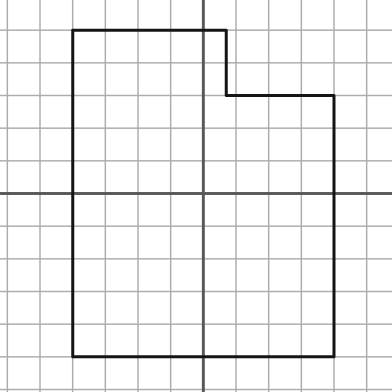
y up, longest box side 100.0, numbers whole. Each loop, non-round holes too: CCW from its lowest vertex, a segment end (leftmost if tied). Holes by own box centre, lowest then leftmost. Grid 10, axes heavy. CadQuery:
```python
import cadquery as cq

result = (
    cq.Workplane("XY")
    .moveTo(-40.0, -50.0)
    .lineTo(40.0, -50.0)
    .lineTo(40.0, 30.0)
    .lineTo(7.0, 30.0)
    .lineTo(7.0, 50.0)
    .lineTo(-40.0, 50.0)
    .close()
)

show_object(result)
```